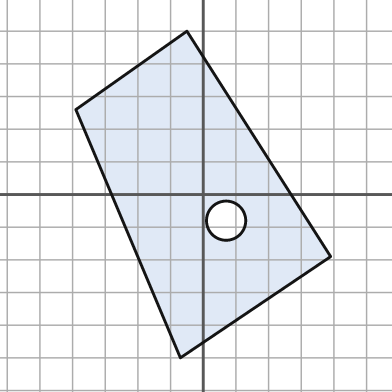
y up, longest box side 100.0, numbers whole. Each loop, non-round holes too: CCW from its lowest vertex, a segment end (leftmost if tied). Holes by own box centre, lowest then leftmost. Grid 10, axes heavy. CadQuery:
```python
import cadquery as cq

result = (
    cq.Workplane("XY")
    .moveTo(-7.0, -50.0)
    .lineTo(39.0, -19.0)
    .lineTo(-5.0, 50.0)
    .lineTo(-39.0, 26.0)
    .close()
    .moveTo(7.0, -8.0)
    .circle(6.0)
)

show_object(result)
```